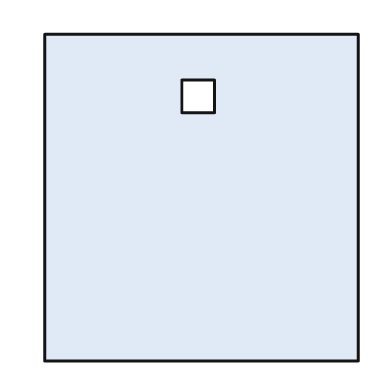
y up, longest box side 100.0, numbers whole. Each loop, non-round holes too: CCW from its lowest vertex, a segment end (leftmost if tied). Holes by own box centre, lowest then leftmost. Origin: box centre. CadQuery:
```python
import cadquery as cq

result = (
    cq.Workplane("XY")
    .moveTo(-48.0, -50.0)
    .lineTo(48.0, -50.0)
    .lineTo(48.0, 50.0)
    .lineTo(-48.0, 50.0)
    .close()
    .moveTo(-6.0, 26.0)
    .lineTo(4.0, 26.0)
    .lineTo(4.0, 36.0)
    .lineTo(-6.0, 36.0)
    .close()
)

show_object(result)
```